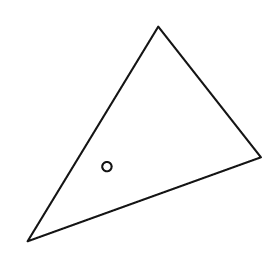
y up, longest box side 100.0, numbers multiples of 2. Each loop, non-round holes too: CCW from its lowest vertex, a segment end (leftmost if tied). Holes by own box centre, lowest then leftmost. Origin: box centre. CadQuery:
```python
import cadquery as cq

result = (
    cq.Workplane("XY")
    .moveTo(-50.0, -46.0)
    .lineTo(50.0, -10.0)
    .lineTo(6.0, 46.0)
    .close()
    .moveTo(-16.0, -14.0)
    .circle(2.0)
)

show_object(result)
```